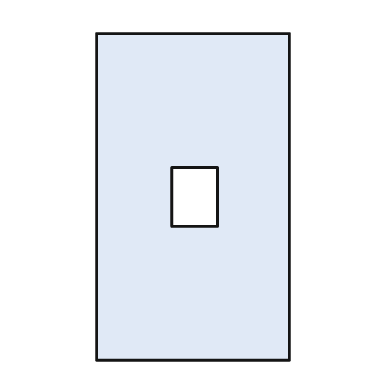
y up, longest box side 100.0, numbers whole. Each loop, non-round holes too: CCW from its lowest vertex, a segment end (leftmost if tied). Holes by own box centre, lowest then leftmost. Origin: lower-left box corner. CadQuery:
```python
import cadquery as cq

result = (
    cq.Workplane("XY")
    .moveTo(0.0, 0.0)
    .lineTo(59.0, 0.0)
    .lineTo(59.0, 100.0)
    .lineTo(0.0, 100.0)
    .close()
    .moveTo(23.0, 41.0)
    .lineTo(37.0, 41.0)
    .lineTo(37.0, 59.0)
    .lineTo(23.0, 59.0)
    .close()
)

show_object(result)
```